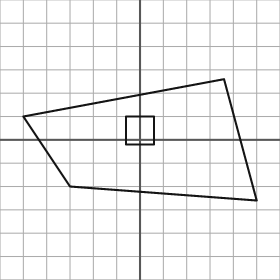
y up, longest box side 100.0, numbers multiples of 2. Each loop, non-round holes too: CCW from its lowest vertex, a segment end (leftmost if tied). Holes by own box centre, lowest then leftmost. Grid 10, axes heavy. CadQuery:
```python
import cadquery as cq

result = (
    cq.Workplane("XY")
    .moveTo(50.0, -26.0)
    .lineTo(36.0, 26.0)
    .lineTo(-50.0, 10.0)
    .lineTo(-30.0, -20.0)
    .close()
    .moveTo(-6.0, -2.0)
    .lineTo(6.0, -2.0)
    .lineTo(6.0, 10.0)
    .lineTo(-6.0, 10.0)
    .close()
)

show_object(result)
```